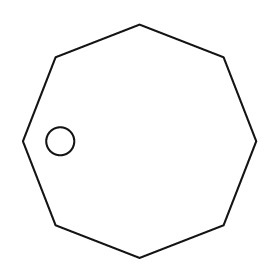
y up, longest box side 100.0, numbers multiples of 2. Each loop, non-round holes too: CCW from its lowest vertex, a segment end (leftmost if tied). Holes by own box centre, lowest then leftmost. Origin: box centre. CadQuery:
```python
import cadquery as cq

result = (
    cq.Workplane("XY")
    .moveTo(0.0, -50.0)
    .lineTo(36.0, -36.0)
    .lineTo(50.0, 0.0)
    .lineTo(36.0, 36.0)
    .lineTo(0.0, 50.0)
    .lineTo(-36.0, 36.0)
    .lineTo(-50.0, 0.0)
    .lineTo(-36.0, -36.0)
    .close()
    .moveTo(-34.0, 0.0)
    .circle(6.0)
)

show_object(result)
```